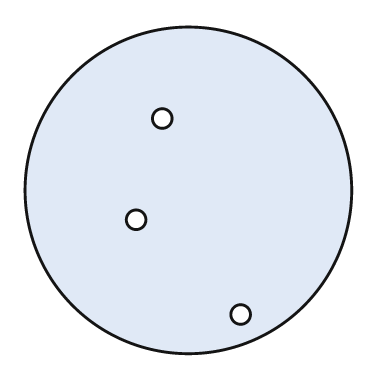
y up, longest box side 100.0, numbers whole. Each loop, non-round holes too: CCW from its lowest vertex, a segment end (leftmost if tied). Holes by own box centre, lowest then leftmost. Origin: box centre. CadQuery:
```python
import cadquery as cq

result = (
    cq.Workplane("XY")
    .moveTo(0.0, 0.0)
    .circle(50.0)
    .moveTo(16.0, -38.0)
    .circle(3.0)
    .moveTo(-16.0, -9.0)
    .circle(3.0)
    .moveTo(-8.0, 22.0)
    .circle(3.0)
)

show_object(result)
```